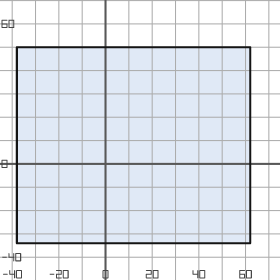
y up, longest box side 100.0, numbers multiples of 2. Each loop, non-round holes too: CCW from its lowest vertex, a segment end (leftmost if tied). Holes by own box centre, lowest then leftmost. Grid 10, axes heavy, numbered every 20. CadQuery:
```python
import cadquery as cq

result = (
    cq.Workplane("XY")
    .moveTo(-38.0, -34.0)
    .lineTo(62.0, -34.0)
    .lineTo(62.0, 50.0)
    .lineTo(-38.0, 50.0)
    .close()
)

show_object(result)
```